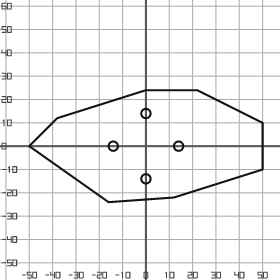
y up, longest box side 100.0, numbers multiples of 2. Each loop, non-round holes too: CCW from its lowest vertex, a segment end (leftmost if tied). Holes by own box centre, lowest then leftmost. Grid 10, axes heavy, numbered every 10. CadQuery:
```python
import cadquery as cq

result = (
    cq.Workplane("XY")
    .moveTo(-16.0, -24.0)
    .lineTo(12.0, -22.0)
    .lineTo(50.0, -10.0)
    .lineTo(50.0, 10.0)
    .lineTo(22.0, 24.0)
    .lineTo(0.0, 24.0)
    .lineTo(-38.0, 12.0)
    .lineTo(-50.0, 0.0)
    .close()
    .moveTo(0.0, -14.0)
    .circle(2.0)
    .moveTo(-14.0, 0.0)
    .circle(2.0)
    .moveTo(14.0, 0.0)
    .circle(2.0)
    .moveTo(0.0, 14.0)
    .circle(2.0)
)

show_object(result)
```